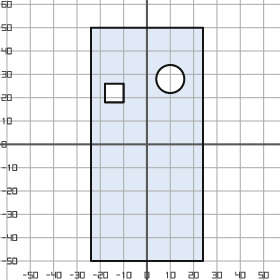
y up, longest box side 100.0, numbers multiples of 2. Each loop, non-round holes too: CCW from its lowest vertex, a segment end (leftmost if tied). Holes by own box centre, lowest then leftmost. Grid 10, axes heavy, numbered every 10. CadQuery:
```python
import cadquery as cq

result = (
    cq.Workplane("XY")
    .moveTo(-24.0, -50.0)
    .lineTo(24.0, -50.0)
    .lineTo(24.0, 50.0)
    .lineTo(-24.0, 50.0)
    .close()
    .moveTo(-18.0, 18.0)
    .lineTo(-10.0, 18.0)
    .lineTo(-10.0, 26.0)
    .lineTo(-18.0, 26.0)
    .close()
    .moveTo(10.0, 28.0)
    .circle(6.0)
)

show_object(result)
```